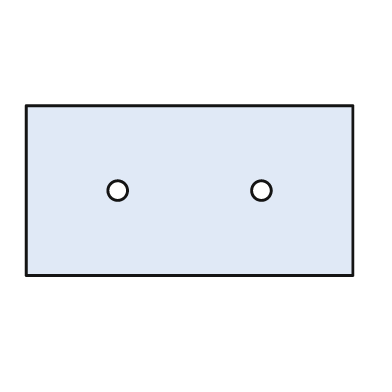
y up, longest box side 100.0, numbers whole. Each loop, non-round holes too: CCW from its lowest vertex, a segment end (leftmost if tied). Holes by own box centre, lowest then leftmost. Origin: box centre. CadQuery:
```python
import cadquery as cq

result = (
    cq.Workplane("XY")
    .moveTo(-50.0, -26.0)
    .lineTo(50.0, -26.0)
    .lineTo(50.0, 26.0)
    .lineTo(-50.0, 26.0)
    .close()
    .moveTo(-22.0, 0.0)
    .circle(3.0)
    .moveTo(22.0, 0.0)
    .circle(3.0)
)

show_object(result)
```